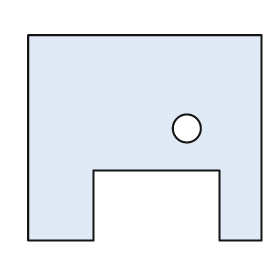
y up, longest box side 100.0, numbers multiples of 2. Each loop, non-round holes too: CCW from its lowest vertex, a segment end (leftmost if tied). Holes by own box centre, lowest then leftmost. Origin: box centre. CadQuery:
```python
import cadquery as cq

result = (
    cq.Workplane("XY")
    .moveTo(-50.0, -44.0)
    .lineTo(-22.0, -44.0)
    .lineTo(-22.0, -14.0)
    .lineTo(32.0, -14.0)
    .lineTo(32.0, -44.0)
    .lineTo(50.0, -44.0)
    .lineTo(50.0, 44.0)
    .lineTo(-50.0, 44.0)
    .close()
    .moveTo(18.0, 4.0)
    .circle(6.0)
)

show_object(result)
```